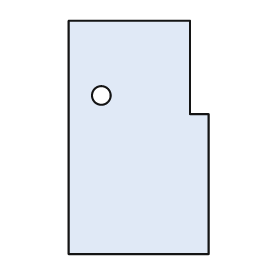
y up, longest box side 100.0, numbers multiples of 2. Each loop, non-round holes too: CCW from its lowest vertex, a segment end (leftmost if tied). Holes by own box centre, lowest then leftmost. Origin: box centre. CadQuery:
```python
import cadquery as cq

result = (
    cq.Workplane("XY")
    .moveTo(-30.0, -50.0)
    .lineTo(30.0, -50.0)
    .lineTo(30.0, 10.0)
    .lineTo(22.0, 10.0)
    .lineTo(22.0, 50.0)
    .lineTo(-30.0, 50.0)
    .close()
    .moveTo(-16.0, 18.0)
    .circle(4.0)
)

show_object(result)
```